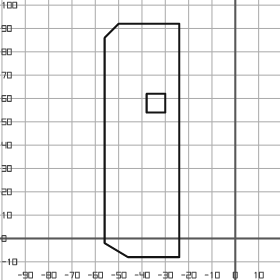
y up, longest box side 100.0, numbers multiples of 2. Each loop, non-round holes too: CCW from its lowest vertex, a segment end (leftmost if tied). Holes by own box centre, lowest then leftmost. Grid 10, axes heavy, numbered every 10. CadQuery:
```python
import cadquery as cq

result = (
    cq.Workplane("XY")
    .moveTo(-46.0, -8.0)
    .lineTo(-24.0, -8.0)
    .lineTo(-24.0, 92.0)
    .lineTo(-50.0, 92.0)
    .lineTo(-56.0, 86.0)
    .lineTo(-56.0, -2.0)
    .close()
    .moveTo(-38.0, 54.0)
    .lineTo(-30.0, 54.0)
    .lineTo(-30.0, 62.0)
    .lineTo(-38.0, 62.0)
    .close()
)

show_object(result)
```